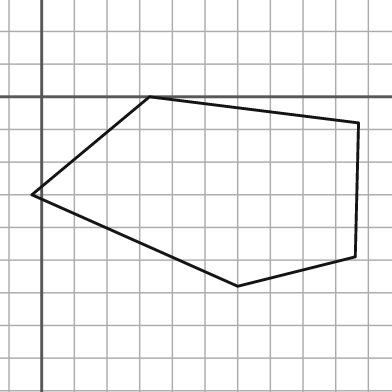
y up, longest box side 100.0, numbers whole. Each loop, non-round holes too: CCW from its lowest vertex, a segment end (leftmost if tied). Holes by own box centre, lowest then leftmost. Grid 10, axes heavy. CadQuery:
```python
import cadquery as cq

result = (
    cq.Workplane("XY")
    .moveTo(60.0, -58.0)
    .lineTo(96.0, -49.0)
    .lineTo(97.0, -8.0)
    .lineTo(33.0, 0.0)
    .lineTo(-3.0, -30.0)
    .close()
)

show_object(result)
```